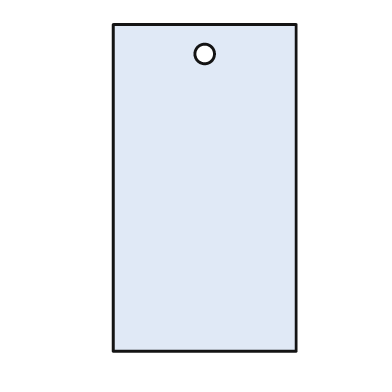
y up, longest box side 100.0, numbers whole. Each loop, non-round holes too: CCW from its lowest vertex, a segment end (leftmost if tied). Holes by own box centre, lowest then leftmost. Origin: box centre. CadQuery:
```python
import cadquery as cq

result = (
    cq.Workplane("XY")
    .moveTo(-28.0, -50.0)
    .lineTo(28.0, -50.0)
    .lineTo(28.0, 50.0)
    .lineTo(-28.0, 50.0)
    .close()
    .moveTo(0.0, 41.0)
    .circle(3.0)
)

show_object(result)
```